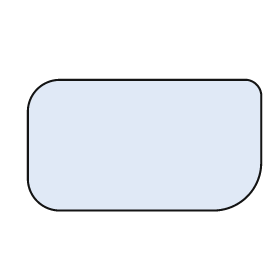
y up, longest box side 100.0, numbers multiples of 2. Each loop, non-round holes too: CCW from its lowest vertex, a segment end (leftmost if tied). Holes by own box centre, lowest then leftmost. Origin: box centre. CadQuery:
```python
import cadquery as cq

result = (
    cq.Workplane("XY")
    .moveTo(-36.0, -28.0)
    .lineTo(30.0, -28.0)
    .threePointArc((44.0, -22.0), (50.0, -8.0))
    .lineTo(50.0, 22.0)
    .threePointArc((48.0, 26.0), (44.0, 28.0))
    .lineTo(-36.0, 28.0)
    .threePointArc((-46.0, 24.0), (-50.0, 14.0))
    .lineTo(-50.0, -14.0)
    .threePointArc((-46.0, -24.0), (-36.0, -28.0))
    .close()
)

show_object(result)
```